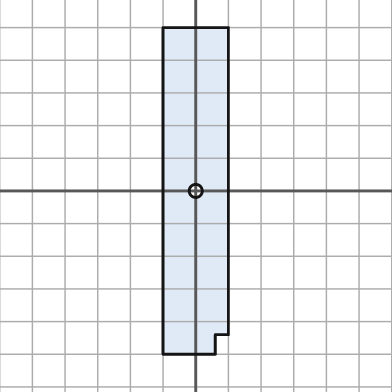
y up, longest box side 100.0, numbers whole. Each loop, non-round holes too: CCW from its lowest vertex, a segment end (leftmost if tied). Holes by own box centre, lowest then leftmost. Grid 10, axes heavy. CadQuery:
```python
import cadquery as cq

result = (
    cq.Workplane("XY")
    .moveTo(-10.0, -50.0)
    .lineTo(6.0, -50.0)
    .lineTo(6.0, -44.0)
    .lineTo(10.0, -44.0)
    .lineTo(10.0, 50.0)
    .lineTo(-10.0, 50.0)
    .close()
    .moveTo(0.0, 0.0)
    .circle(2.0)
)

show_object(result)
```